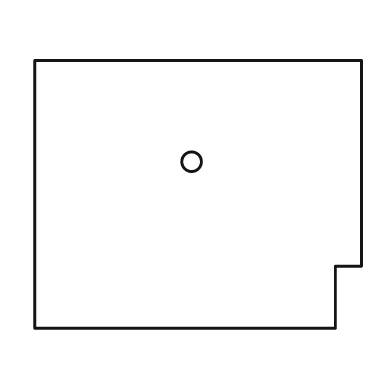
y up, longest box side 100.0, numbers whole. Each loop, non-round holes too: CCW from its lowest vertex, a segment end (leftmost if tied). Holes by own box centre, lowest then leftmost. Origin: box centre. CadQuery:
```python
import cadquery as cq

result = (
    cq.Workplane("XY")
    .moveTo(-50.0, -41.0)
    .lineTo(42.0, -41.0)
    .lineTo(42.0, -22.0)
    .lineTo(50.0, -22.0)
    .lineTo(50.0, 41.0)
    .lineTo(-50.0, 41.0)
    .close()
    .moveTo(-2.0, 10.0)
    .circle(3.0)
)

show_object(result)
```